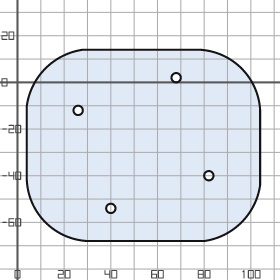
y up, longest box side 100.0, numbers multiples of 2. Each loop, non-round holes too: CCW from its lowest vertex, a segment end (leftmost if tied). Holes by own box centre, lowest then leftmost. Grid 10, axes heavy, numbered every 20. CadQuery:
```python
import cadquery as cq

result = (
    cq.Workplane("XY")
    .moveTo(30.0, -68.0)
    .lineTo(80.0, -68.0)
    .threePointArc((96.0, -60.0), (104.0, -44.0))
    .lineTo(104.0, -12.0)
    .threePointArc((96.0, 6.0), (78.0, 14.0))
    .lineTo(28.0, 14.0)
    .threePointArc((12.0, 6.0), (4.0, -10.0))
    .lineTo(4.0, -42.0)
    .threePointArc((12.0, -60.0), (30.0, -68.0))
    .close()
    .moveTo(40.0, -54.0)
    .circle(2.0)
    .moveTo(82.0, -40.0)
    .circle(2.0)
    .moveTo(26.0, -12.0)
    .circle(2.0)
    .moveTo(68.0, 2.0)
    .circle(2.0)
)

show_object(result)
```